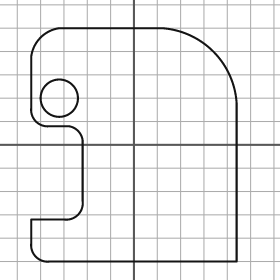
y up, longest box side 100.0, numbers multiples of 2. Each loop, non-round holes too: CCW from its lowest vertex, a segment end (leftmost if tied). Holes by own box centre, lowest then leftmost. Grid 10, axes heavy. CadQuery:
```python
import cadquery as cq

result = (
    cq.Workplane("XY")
    .moveTo(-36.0, -50.0)
    .lineTo(44.0, -50.0)
    .lineTo(44.0, 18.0)
    .threePointArc((34.0, 40.0), (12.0, 50.0))
    .lineTo(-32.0, 50.0)
    .threePointArc((-40.0, 46.0), (-44.0, 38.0))
    .lineTo(-44.0, 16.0)
    .threePointArc((-42.0, 10.0), (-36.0, 8.0))
    .lineTo(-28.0, 8.0)
    .threePointArc((-24.0, 6.0), (-22.0, 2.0))
    .lineTo(-22.0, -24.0)
    .threePointArc((-24.0, -30.0), (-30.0, -32.0))
    .lineTo(-44.0, -32.0)
    .lineTo(-44.0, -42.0)
    .threePointArc((-42.0, -48.0), (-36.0, -50.0))
    .close()
    .moveTo(-32.0, 20.0)
    .circle(8.0)
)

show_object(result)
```